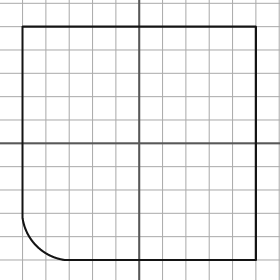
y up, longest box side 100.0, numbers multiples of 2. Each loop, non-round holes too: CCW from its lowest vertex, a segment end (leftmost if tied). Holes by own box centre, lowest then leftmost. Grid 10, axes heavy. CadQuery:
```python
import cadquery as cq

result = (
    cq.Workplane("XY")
    .moveTo(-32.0, -50.0)
    .lineTo(50.0, -50.0)
    .lineTo(50.0, 50.0)
    .lineTo(-50.0, 50.0)
    .lineTo(-50.0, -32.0)
    .threePointArc((-44.0, -44.0), (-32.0, -50.0))
    .close()
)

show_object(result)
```